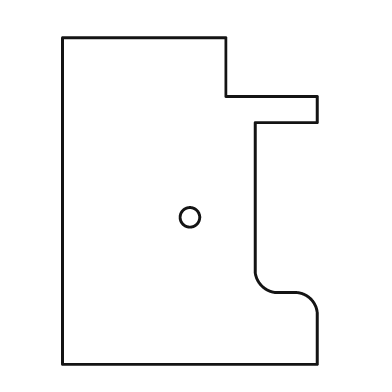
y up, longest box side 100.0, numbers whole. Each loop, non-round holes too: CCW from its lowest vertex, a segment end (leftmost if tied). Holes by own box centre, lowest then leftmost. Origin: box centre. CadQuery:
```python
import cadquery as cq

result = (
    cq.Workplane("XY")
    .moveTo(-39.0, -50.0)
    .lineTo(39.0, -50.0)
    .lineTo(39.0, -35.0)
    .threePointArc((37.0, -30.0), (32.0, -28.0))
    .lineTo(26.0, -28.0)
    .threePointArc((22.0, -26.0), (20.0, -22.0))
    .lineTo(20.0, 24.0)
    .lineTo(39.0, 24.0)
    .lineTo(39.0, 32.0)
    .lineTo(11.0, 32.0)
    .lineTo(11.0, 50.0)
    .lineTo(-39.0, 50.0)
    .close()
    .moveTo(0.0, -5.0)
    .circle(3.0)
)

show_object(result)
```